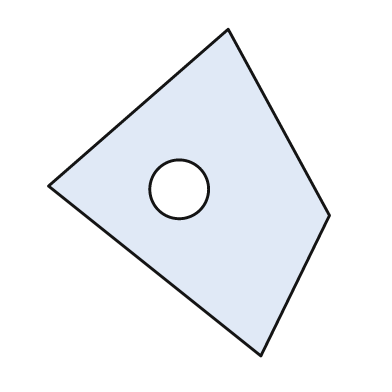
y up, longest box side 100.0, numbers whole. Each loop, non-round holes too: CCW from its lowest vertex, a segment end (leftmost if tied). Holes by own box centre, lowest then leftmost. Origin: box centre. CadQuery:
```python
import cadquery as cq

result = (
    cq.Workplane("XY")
    .moveTo(22.0, -50.0)
    .lineTo(43.0, -7.0)
    .lineTo(12.0, 50.0)
    .lineTo(-43.0, 2.0)
    .close()
    .moveTo(-3.0, 1.0)
    .circle(9.0)
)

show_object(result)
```